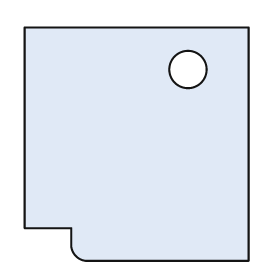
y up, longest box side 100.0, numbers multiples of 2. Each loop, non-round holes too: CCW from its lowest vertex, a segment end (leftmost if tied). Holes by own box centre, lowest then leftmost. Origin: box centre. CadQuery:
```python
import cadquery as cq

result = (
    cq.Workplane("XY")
    .moveTo(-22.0, -50.0)
    .lineTo(48.0, -50.0)
    .lineTo(48.0, 50.0)
    .lineTo(-48.0, 50.0)
    .lineTo(-48.0, -36.0)
    .lineTo(-28.0, -36.0)
    .lineTo(-28.0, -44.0)
    .threePointArc((-26.0, -48.0), (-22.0, -50.0))
    .close()
    .moveTo(22.0, 32.0)
    .circle(8.0)
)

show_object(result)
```